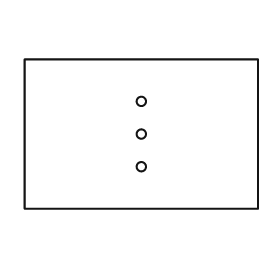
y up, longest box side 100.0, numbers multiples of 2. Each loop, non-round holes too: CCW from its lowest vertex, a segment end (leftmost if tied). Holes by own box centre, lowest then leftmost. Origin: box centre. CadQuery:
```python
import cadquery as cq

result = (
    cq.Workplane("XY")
    .moveTo(-50.0, -32.0)
    .lineTo(50.0, -32.0)
    .lineTo(50.0, 32.0)
    .lineTo(-50.0, 32.0)
    .close()
    .moveTo(0.0, -14.0)
    .circle(2.0)
    .moveTo(0.0, 0.0)
    .circle(2.0)
    .moveTo(0.0, 14.0)
    .circle(2.0)
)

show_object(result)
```